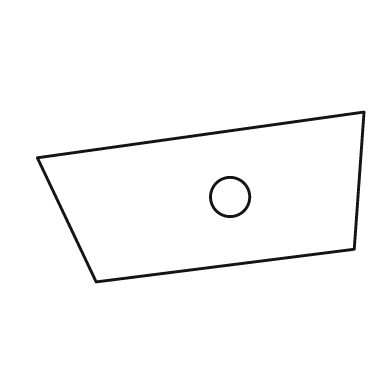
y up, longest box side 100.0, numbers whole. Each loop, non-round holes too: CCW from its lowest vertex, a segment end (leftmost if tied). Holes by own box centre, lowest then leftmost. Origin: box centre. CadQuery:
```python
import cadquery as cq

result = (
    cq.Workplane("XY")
    .moveTo(-32.0, -26.0)
    .lineTo(47.0, -16.0)
    .lineTo(50.0, 26.0)
    .lineTo(-50.0, 12.0)
    .close()
    .moveTo(9.0, 0.0)
    .circle(6.0)
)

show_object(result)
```